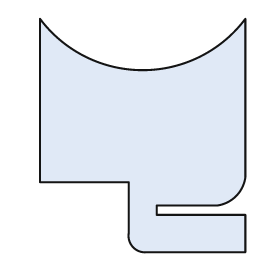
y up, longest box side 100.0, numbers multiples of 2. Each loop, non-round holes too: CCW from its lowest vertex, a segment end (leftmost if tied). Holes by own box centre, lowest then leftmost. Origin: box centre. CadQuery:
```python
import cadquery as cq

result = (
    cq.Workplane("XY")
    .moveTo(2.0, -50.0)
    .lineTo(44.0, -50.0)
    .lineTo(44.0, -34.0)
    .lineTo(6.0, -34.0)
    .lineTo(6.0, -30.0)
    .lineTo(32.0, -30.0)
    .threePointArc((40.0, -26.0), (44.0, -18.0))
    .lineTo(44.0, 50.0)
    .threePointArc((0.0, 28.0), (-44.0, 50.0))
    .lineTo(-44.0, -20.0)
    .lineTo(-6.0, -20.0)
    .lineTo(-6.0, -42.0)
    .threePointArc((-4.0, -48.0), (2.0, -50.0))
    .close()
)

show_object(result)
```